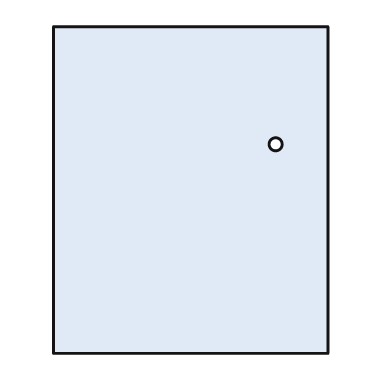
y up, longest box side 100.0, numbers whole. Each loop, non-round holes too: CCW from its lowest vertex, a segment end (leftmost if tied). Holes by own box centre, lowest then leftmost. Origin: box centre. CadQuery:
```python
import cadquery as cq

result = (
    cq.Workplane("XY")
    .moveTo(-42.0, -50.0)
    .lineTo(42.0, -50.0)
    .lineTo(42.0, 50.0)
    .lineTo(-42.0, 50.0)
    .close()
    .moveTo(26.0, 14.0)
    .circle(2.0)
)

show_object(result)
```